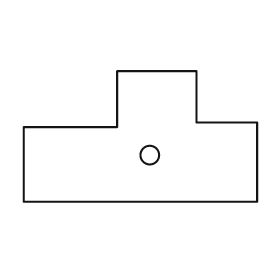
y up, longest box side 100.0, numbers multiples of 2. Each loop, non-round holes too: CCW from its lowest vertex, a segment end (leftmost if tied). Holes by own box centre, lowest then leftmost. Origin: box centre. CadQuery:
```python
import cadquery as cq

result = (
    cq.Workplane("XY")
    .moveTo(-50.0, -28.0)
    .lineTo(50.0, -28.0)
    .lineTo(50.0, 6.0)
    .lineTo(24.0, 6.0)
    .lineTo(24.0, 28.0)
    .lineTo(-10.0, 28.0)
    .lineTo(-10.0, 4.0)
    .lineTo(-50.0, 4.0)
    .close()
    .moveTo(4.0, -8.0)
    .circle(4.0)
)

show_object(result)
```